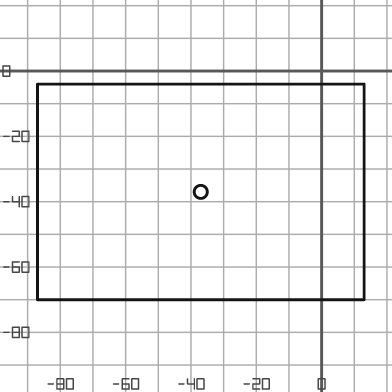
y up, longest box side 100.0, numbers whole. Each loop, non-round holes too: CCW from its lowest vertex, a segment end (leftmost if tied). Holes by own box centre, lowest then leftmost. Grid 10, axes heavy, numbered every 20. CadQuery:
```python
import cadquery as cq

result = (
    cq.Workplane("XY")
    .moveTo(-87.0, -70.0)
    .lineTo(13.0, -70.0)
    .lineTo(13.0, -4.0)
    .lineTo(-87.0, -4.0)
    .close()
    .moveTo(-37.0, -37.0)
    .circle(2.0)
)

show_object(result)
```